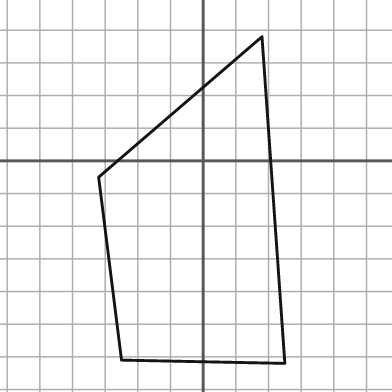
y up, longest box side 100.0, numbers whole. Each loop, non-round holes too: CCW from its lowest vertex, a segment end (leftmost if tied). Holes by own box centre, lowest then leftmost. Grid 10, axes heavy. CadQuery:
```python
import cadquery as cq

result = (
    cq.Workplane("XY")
    .moveTo(25.0, -62.0)
    .lineTo(18.0, 38.0)
    .lineTo(-32.0, -5.0)
    .lineTo(-25.0, -61.0)
    .close()
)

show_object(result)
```